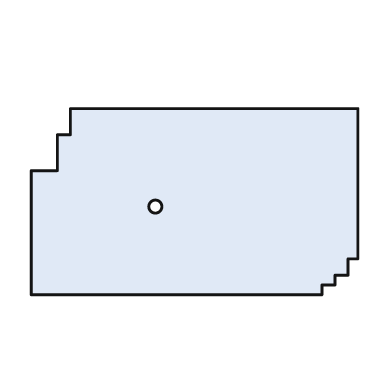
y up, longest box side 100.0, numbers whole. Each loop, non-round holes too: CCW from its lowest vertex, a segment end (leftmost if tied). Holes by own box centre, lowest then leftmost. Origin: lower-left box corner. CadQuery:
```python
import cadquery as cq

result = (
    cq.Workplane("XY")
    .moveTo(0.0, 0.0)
    .lineTo(89.0, 0.0)
    .lineTo(89.0, 3.0)
    .lineTo(93.0, 3.0)
    .lineTo(93.0, 6.0)
    .lineTo(97.0, 6.0)
    .lineTo(97.0, 11.0)
    .lineTo(100.0, 11.0)
    .lineTo(100.0, 57.0)
    .lineTo(12.0, 57.0)
    .lineTo(12.0, 49.0)
    .lineTo(8.0, 49.0)
    .lineTo(8.0, 38.0)
    .lineTo(0.0, 38.0)
    .close()
    .moveTo(38.0, 27.0)
    .circle(2.0)
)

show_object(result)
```